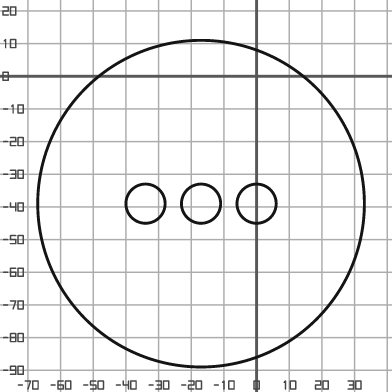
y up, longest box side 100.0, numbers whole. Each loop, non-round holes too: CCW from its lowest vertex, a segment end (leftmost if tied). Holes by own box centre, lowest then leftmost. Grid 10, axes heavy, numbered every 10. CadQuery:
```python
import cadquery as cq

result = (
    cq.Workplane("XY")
    .moveTo(-17.0, -39.0)
    .circle(50.0)
    .moveTo(-34.0, -39.0)
    .circle(6.0)
    .moveTo(-17.0, -39.0)
    .circle(6.0)
    .moveTo(0.0, -39.0)
    .circle(6.0)
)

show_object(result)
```